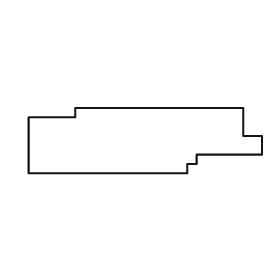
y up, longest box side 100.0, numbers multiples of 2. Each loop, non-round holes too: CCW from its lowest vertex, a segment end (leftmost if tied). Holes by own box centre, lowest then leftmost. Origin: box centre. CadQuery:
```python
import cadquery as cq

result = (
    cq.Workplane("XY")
    .moveTo(-50.0, -14.0)
    .lineTo(18.0, -14.0)
    .lineTo(18.0, -10.0)
    .lineTo(22.0, -10.0)
    .lineTo(22.0, -6.0)
    .lineTo(50.0, -6.0)
    .lineTo(50.0, 2.0)
    .lineTo(42.0, 2.0)
    .lineTo(42.0, 14.0)
    .lineTo(-30.0, 14.0)
    .lineTo(-30.0, 10.0)
    .lineTo(-50.0, 10.0)
    .close()
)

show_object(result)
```